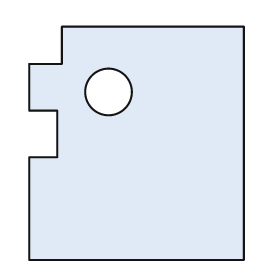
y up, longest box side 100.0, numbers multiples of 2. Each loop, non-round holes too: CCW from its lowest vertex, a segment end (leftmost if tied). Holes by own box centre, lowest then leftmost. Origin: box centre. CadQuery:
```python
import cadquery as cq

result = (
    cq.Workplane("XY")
    .moveTo(-46.0, -50.0)
    .lineTo(46.0, -50.0)
    .lineTo(46.0, 50.0)
    .lineTo(-32.0, 50.0)
    .lineTo(-32.0, 34.0)
    .lineTo(-46.0, 34.0)
    .lineTo(-46.0, 14.0)
    .lineTo(-34.0, 14.0)
    .lineTo(-34.0, -6.0)
    .lineTo(-46.0, -6.0)
    .close()
    .moveTo(-12.0, 22.0)
    .circle(10.0)
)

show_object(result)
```